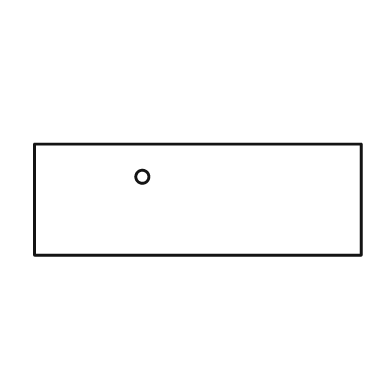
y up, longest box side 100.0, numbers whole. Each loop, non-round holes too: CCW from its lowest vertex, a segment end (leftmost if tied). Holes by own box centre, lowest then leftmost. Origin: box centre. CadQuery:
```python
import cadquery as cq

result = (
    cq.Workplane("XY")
    .moveTo(-50.0, -17.0)
    .lineTo(50.0, -17.0)
    .lineTo(50.0, 17.0)
    .lineTo(-50.0, 17.0)
    .close()
    .moveTo(-17.0, 7.0)
    .circle(2.0)
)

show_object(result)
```